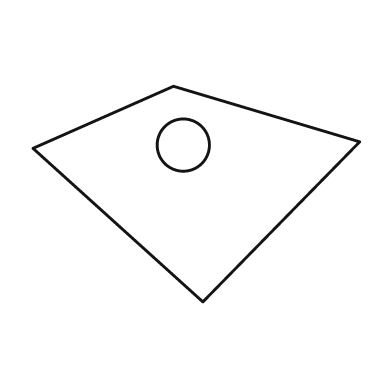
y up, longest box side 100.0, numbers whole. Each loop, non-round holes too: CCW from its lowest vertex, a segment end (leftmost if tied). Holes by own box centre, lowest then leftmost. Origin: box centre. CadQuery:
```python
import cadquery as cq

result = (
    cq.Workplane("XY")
    .moveTo(2.0, -33.0)
    .lineTo(50.0, 16.0)
    .lineTo(-7.0, 33.0)
    .lineTo(-50.0, 14.0)
    .close()
    .moveTo(-4.0, 15.0)
    .circle(8.0)
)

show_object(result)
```